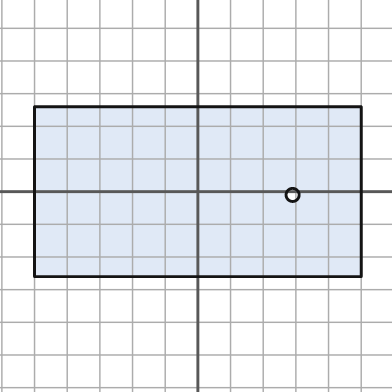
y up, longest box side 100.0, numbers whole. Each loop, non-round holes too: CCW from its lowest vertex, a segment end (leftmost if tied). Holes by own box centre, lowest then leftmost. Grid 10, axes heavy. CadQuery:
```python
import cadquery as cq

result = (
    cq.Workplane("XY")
    .moveTo(-50.0, -26.0)
    .lineTo(50.0, -26.0)
    .lineTo(50.0, 26.0)
    .lineTo(-50.0, 26.0)
    .close()
    .moveTo(29.0, -1.0)
    .circle(2.0)
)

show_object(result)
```